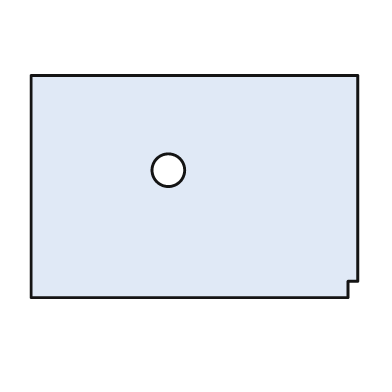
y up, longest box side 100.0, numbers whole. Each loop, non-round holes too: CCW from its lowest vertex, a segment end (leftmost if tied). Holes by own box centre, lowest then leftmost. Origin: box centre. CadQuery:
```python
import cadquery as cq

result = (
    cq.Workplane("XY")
    .moveTo(-50.0, -34.0)
    .lineTo(47.0, -34.0)
    .lineTo(47.0, -29.0)
    .lineTo(50.0, -29.0)
    .lineTo(50.0, 34.0)
    .lineTo(-50.0, 34.0)
    .close()
    .moveTo(-8.0, 5.0)
    .circle(5.0)
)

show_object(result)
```